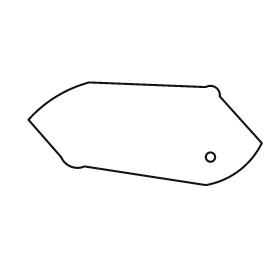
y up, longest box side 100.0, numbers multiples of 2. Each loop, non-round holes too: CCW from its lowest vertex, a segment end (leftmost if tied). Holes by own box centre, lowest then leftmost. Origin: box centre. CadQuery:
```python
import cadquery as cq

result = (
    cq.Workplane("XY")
    .moveTo(26.0, -22.0)
    .threePointArc((40.0, -16.0), (50.0, -4.0))
    .lineTo(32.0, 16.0)
    .threePointArc((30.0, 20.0), (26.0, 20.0))
    .lineTo(-24.0, 22.0)
    .threePointArc((-38.0, 16.0), (-50.0, 6.0))
    .lineTo(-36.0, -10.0)
    .threePointArc((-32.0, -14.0), (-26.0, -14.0))
    .close()
    .moveTo(28.0, -10.0)
    .circle(2.0)
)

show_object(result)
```